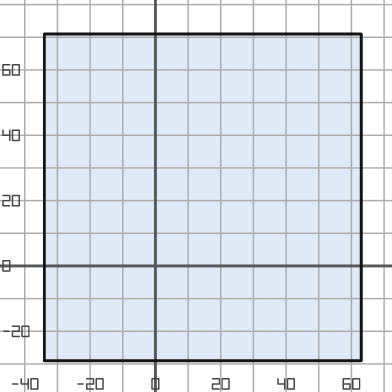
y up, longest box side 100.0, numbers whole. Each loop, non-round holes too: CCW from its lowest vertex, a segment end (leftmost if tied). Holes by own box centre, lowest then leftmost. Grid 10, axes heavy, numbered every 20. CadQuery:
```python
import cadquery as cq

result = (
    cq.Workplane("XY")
    .moveTo(-34.0, -29.0)
    .lineTo(63.0, -29.0)
    .lineTo(63.0, 71.0)
    .lineTo(-34.0, 71.0)
    .close()
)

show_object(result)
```